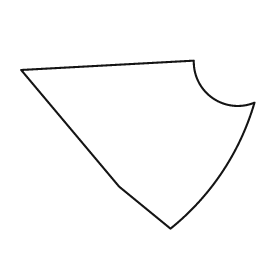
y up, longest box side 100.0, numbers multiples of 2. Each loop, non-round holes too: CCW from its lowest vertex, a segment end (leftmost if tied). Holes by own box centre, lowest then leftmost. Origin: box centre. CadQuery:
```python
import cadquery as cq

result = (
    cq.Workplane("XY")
    .moveTo(14.0, -36.0)
    .threePointArc((36.0, -12.0), (50.0, 18.0))
    .threePointArc((32.0, 20.0), (24.0, 36.0))
    .lineTo(-50.0, 32.0)
    .lineTo(-8.0, -18.0)
    .close()
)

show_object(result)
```